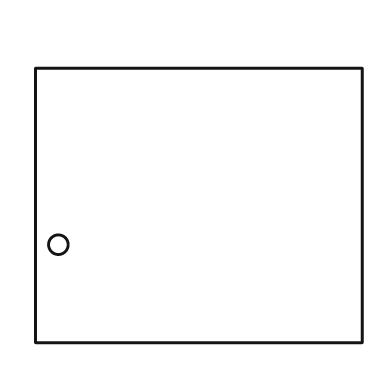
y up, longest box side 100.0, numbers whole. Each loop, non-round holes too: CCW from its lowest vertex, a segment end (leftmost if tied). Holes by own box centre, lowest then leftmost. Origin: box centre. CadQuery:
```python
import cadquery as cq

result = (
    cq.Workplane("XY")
    .moveTo(-50.0, -42.0)
    .lineTo(50.0, -42.0)
    .lineTo(50.0, 42.0)
    .lineTo(-50.0, 42.0)
    .close()
    .moveTo(-43.0, -12.0)
    .circle(3.0)
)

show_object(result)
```